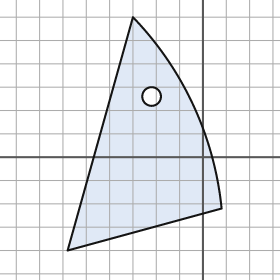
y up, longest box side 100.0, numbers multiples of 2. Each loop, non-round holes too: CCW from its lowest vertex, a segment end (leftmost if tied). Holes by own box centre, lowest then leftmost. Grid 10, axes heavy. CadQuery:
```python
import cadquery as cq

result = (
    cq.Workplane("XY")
    .moveTo(-58.0, -40.0)
    .lineTo(8.0, -22.0)
    .threePointArc((-4.0, 22.0), (-30.0, 60.0))
    .close()
    .moveTo(-22.0, 26.0)
    .circle(4.0)
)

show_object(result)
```